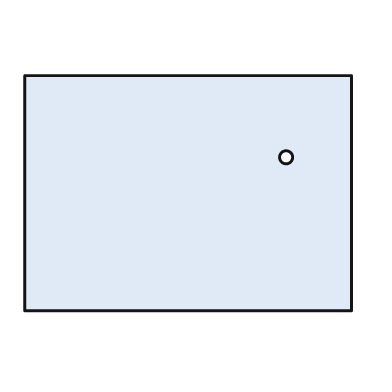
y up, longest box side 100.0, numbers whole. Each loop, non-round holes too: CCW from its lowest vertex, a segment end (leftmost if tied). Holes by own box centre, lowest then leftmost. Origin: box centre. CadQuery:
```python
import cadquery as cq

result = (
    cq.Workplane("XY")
    .moveTo(-50.0, -36.0)
    .lineTo(50.0, -36.0)
    .lineTo(50.0, 36.0)
    .lineTo(-50.0, 36.0)
    .close()
    .moveTo(30.0, 11.0)
    .circle(2.0)
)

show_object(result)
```